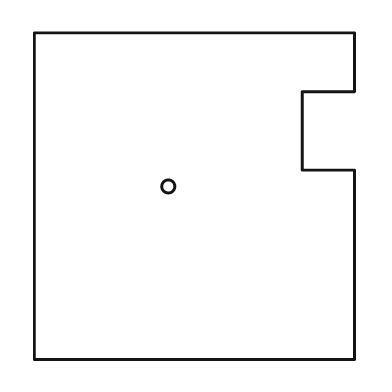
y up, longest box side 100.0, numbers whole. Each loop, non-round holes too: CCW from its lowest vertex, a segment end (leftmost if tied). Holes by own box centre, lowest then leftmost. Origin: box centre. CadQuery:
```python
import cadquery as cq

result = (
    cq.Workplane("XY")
    .moveTo(-49.0, -50.0)
    .lineTo(49.0, -50.0)
    .lineTo(49.0, 8.0)
    .lineTo(33.0, 8.0)
    .lineTo(33.0, 32.0)
    .lineTo(49.0, 32.0)
    .lineTo(49.0, 50.0)
    .lineTo(-49.0, 50.0)
    .close()
    .moveTo(-8.0, 3.0)
    .circle(2.0)
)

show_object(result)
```